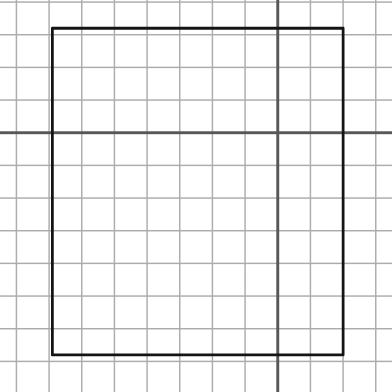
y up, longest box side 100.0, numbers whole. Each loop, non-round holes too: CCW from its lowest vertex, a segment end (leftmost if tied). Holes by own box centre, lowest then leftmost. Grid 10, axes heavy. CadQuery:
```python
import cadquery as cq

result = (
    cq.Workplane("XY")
    .moveTo(-69.0, -68.0)
    .lineTo(20.0, -68.0)
    .lineTo(20.0, 32.0)
    .lineTo(-69.0, 32.0)
    .close()
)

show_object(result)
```